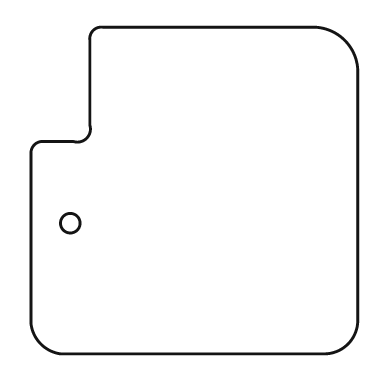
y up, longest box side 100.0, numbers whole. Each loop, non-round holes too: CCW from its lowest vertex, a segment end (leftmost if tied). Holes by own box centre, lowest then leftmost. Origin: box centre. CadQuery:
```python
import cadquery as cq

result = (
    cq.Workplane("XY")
    .moveTo(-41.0, -50.0)
    .lineTo(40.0, -50.0)
    .threePointArc((47.0, -47.0), (50.0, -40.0))
    .lineTo(50.0, 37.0)
    .threePointArc((46.0, 46.0), (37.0, 50.0))
    .lineTo(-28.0, 50.0)
    .threePointArc((-31.0, 49.0), (-32.0, 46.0))
    .lineTo(-32.0, 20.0)
    .threePointArc((-33.0, 16.0), (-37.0, 15.0))
    .lineTo(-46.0, 15.0)
    .threePointArc((-49.0, 14.0), (-50.0, 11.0))
    .lineTo(-50.0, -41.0)
    .threePointArc((-47.0, -47.0), (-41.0, -50.0))
    .close()
    .moveTo(-38.0, -10.0)
    .circle(3.0)
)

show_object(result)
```